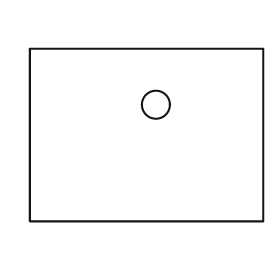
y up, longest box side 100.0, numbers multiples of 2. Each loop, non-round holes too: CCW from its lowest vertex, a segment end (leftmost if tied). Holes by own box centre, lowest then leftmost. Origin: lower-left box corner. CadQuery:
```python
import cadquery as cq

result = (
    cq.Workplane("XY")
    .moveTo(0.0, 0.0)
    .lineTo(100.0, 0.0)
    .lineTo(100.0, 74.0)
    .lineTo(0.0, 74.0)
    .close()
    .moveTo(54.0, 50.0)
    .circle(6.0)
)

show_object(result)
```